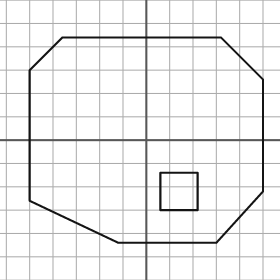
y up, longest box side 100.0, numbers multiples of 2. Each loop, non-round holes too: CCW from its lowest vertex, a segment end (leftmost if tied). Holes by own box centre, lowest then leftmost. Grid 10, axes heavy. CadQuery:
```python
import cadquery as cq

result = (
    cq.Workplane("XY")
    .moveTo(-12.0, -44.0)
    .lineTo(30.0, -44.0)
    .lineTo(50.0, -22.0)
    .lineTo(50.0, 26.0)
    .lineTo(32.0, 44.0)
    .lineTo(-36.0, 44.0)
    .lineTo(-50.0, 30.0)
    .lineTo(-50.0, -26.0)
    .close()
    .moveTo(6.0, -30.0)
    .lineTo(22.0, -30.0)
    .lineTo(22.0, -14.0)
    .lineTo(6.0, -14.0)
    .close()
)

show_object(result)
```